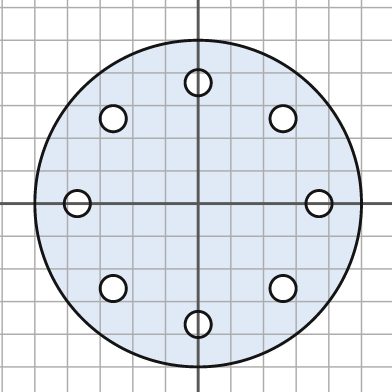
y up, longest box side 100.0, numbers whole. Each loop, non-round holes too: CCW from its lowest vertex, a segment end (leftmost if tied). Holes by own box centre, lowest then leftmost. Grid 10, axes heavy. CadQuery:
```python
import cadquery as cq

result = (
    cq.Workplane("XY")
    .moveTo(0.0, 0.0)
    .circle(50.0)
    .moveTo(0.0, -37.0)
    .circle(4.0)
    .moveTo(-26.0, -26.0)
    .circle(4.0)
    .moveTo(26.0, -26.0)
    .circle(4.0)
    .moveTo(-37.0, 0.0)
    .circle(4.0)
    .moveTo(37.0, 0.0)
    .circle(4.0)
    .moveTo(-26.0, 26.0)
    .circle(4.0)
    .moveTo(26.0, 26.0)
    .circle(4.0)
    .moveTo(0.0, 37.0)
    .circle(4.0)
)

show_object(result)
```